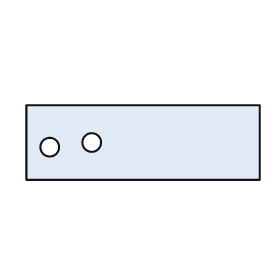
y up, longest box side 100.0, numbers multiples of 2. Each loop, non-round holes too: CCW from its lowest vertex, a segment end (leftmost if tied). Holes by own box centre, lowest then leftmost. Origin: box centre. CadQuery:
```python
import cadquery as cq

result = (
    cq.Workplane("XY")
    .moveTo(-50.0, -16.0)
    .lineTo(50.0, -16.0)
    .lineTo(50.0, 16.0)
    .lineTo(-50.0, 16.0)
    .close()
    .moveTo(-40.0, -2.0)
    .circle(4.0)
    .moveTo(-22.0, 0.0)
    .circle(4.0)
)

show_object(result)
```